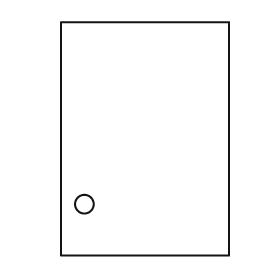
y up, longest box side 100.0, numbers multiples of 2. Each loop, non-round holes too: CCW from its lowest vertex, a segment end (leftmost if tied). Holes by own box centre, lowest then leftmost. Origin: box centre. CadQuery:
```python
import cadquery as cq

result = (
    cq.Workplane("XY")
    .moveTo(-36.0, -50.0)
    .lineTo(36.0, -50.0)
    .lineTo(36.0, 50.0)
    .lineTo(-36.0, 50.0)
    .close()
    .moveTo(-26.0, -28.0)
    .circle(4.0)
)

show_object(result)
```